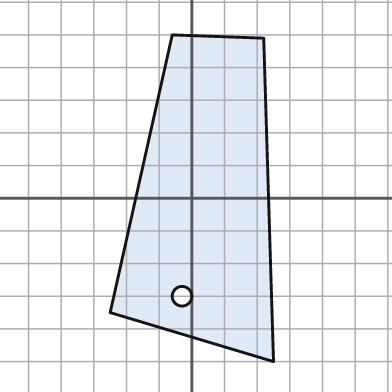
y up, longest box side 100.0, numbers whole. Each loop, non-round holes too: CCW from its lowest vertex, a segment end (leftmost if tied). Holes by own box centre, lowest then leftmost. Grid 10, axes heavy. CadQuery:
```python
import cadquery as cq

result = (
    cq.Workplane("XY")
    .moveTo(25.0, -50.0)
    .lineTo(22.0, 49.0)
    .lineTo(-6.0, 50.0)
    .lineTo(-25.0, -35.0)
    .close()
    .moveTo(-3.0, -30.0)
    .circle(3.0)
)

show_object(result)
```